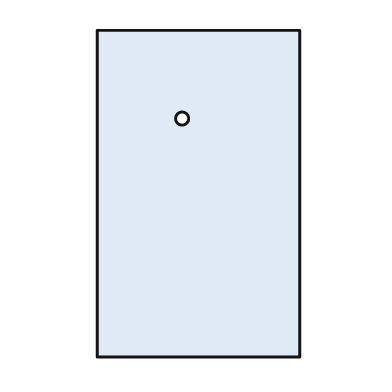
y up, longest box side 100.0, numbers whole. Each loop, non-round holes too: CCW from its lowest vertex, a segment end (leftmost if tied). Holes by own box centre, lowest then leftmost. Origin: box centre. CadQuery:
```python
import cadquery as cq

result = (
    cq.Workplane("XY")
    .moveTo(-31.0, -50.0)
    .lineTo(31.0, -50.0)
    .lineTo(31.0, 50.0)
    .lineTo(-31.0, 50.0)
    .close()
    .moveTo(-5.0, 23.0)
    .circle(2.0)
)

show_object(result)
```